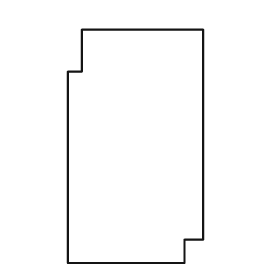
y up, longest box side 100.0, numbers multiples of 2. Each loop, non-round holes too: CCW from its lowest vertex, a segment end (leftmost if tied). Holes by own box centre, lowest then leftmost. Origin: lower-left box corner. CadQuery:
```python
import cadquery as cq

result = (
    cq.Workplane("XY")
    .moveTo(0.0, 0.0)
    .lineTo(50.0, 0.0)
    .lineTo(50.0, 10.0)
    .lineTo(58.0, 10.0)
    .lineTo(58.0, 100.0)
    .lineTo(6.0, 100.0)
    .lineTo(6.0, 82.0)
    .lineTo(0.0, 82.0)
    .close()
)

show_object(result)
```